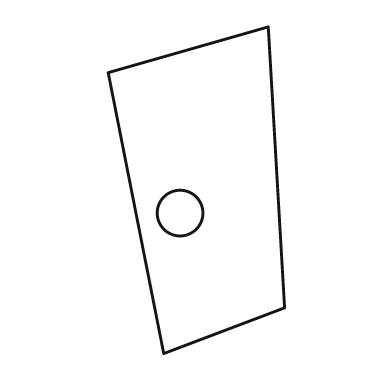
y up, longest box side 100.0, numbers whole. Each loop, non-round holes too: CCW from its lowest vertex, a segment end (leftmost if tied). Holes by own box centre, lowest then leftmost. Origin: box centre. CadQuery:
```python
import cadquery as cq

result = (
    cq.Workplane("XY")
    .moveTo(-10.0, -50.0)
    .lineTo(27.0, -36.0)
    .lineTo(22.0, 50.0)
    .lineTo(-27.0, 36.0)
    .close()
    .moveTo(-5.0, -7.0)
    .circle(7.0)
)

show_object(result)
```